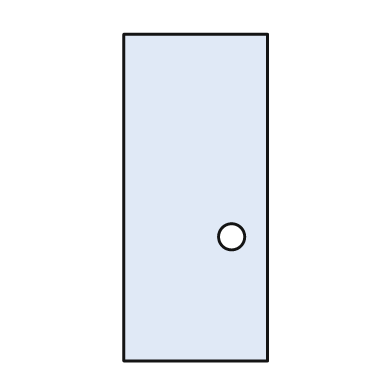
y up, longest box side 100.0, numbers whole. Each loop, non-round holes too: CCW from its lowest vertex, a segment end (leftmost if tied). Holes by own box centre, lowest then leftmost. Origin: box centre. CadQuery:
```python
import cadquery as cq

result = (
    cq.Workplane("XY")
    .moveTo(-22.0, -50.0)
    .lineTo(22.0, -50.0)
    .lineTo(22.0, 50.0)
    .lineTo(-22.0, 50.0)
    .close()
    .moveTo(11.0, -12.0)
    .circle(4.0)
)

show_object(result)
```